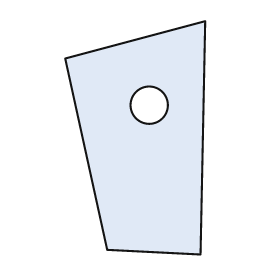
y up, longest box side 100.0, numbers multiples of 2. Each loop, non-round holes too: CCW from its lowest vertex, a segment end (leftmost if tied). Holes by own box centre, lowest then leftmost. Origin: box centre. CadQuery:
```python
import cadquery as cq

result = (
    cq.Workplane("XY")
    .moveTo(28.0, -50.0)
    .lineTo(30.0, 50.0)
    .lineTo(-30.0, 34.0)
    .lineTo(-12.0, -48.0)
    .close()
    .moveTo(6.0, 14.0)
    .circle(8.0)
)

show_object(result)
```